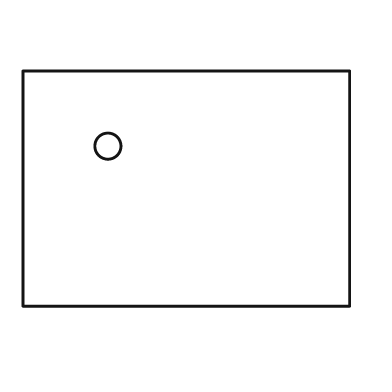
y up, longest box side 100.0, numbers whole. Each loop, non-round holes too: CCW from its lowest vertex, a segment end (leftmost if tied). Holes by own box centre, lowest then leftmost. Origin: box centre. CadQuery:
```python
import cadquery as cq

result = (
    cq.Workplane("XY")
    .moveTo(-50.0, -36.0)
    .lineTo(50.0, -36.0)
    .lineTo(50.0, 36.0)
    .lineTo(-50.0, 36.0)
    .close()
    .moveTo(-24.0, 13.0)
    .circle(4.0)
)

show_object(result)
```